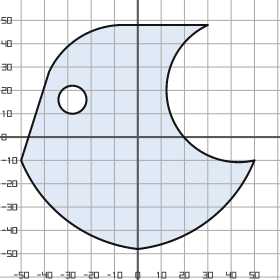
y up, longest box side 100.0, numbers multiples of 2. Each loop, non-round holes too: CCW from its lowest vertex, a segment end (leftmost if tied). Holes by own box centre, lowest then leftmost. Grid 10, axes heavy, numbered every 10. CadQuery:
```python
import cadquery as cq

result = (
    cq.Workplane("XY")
    .moveTo(0.0, -48.0)
    .threePointArc((30.0, -36.0), (50.0, -10.0))
    .threePointArc((14.0, 10.0), (30.0, 48.0))
    .lineTo(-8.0, 48.0)
    .threePointArc((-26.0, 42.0), (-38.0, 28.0))
    .lineTo(-50.0, -10.0)
    .threePointArc((-30.0, -36.0), (0.0, -48.0))
    .close()
    .moveTo(-28.0, 16.0)
    .circle(6.0)
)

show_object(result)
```